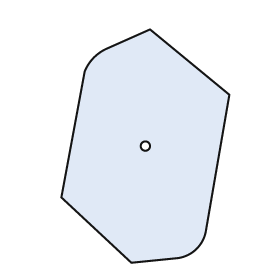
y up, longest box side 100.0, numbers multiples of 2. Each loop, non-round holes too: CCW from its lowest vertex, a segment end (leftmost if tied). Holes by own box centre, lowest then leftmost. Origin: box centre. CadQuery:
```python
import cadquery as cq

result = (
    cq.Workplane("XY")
    .moveTo(-6.0, -50.0)
    .lineTo(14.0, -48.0)
    .threePointArc((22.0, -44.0), (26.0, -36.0))
    .lineTo(36.0, 22.0)
    .lineTo(2.0, 50.0)
    .lineTo(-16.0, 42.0)
    .threePointArc((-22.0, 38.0), (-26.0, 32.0))
    .lineTo(-36.0, -22.0)
    .close()
    .moveTo(0.0, 0.0)
    .circle(2.0)
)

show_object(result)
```